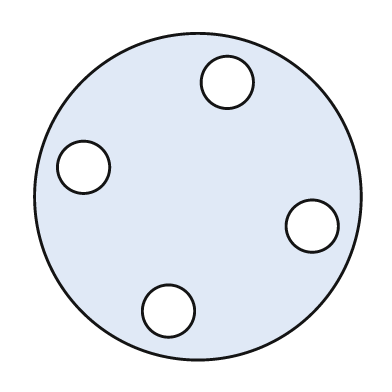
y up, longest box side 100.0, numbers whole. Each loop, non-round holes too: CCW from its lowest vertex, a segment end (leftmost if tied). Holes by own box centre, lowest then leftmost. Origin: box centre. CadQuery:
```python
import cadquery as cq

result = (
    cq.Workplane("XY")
    .moveTo(0.0, 0.0)
    .circle(50.0)
    .moveTo(-9.0, -35.0)
    .circle(8.0)
    .moveTo(35.0, -9.0)
    .circle(8.0)
    .moveTo(-35.0, 9.0)
    .circle(8.0)
    .moveTo(9.0, 35.0)
    .circle(8.0)
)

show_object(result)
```